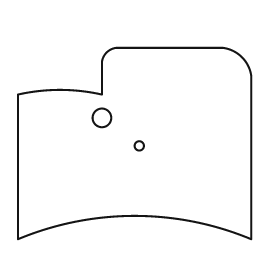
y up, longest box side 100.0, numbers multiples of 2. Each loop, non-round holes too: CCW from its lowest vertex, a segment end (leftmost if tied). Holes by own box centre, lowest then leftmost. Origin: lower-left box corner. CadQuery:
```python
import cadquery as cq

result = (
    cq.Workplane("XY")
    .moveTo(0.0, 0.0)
    .threePointArc((50.0, 10.0), (100.0, 0.0))
    .lineTo(100.0, 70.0)
    .threePointArc((96.0, 78.0), (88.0, 82.0))
    .lineTo(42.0, 82.0)
    .threePointArc((38.0, 80.0), (36.0, 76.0))
    .lineTo(36.0, 62.0)
    .threePointArc((18.0, 64.0), (0.0, 62.0))
    .close()
    .moveTo(52.0, 40.0)
    .circle(2.0)
    .moveTo(36.0, 52.0)
    .circle(4.0)
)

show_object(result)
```